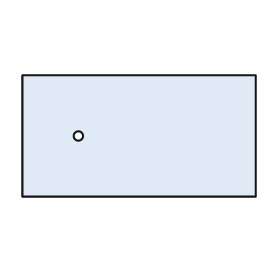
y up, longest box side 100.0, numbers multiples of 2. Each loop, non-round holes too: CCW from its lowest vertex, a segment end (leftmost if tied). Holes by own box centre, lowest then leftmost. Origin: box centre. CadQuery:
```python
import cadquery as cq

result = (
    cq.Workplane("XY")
    .moveTo(-50.0, -26.0)
    .lineTo(50.0, -26.0)
    .lineTo(50.0, 26.0)
    .lineTo(-50.0, 26.0)
    .close()
    .moveTo(-26.0, 0.0)
    .circle(2.0)
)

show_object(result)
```